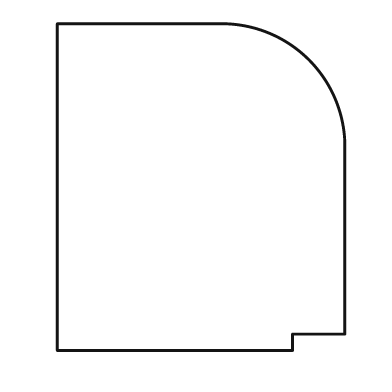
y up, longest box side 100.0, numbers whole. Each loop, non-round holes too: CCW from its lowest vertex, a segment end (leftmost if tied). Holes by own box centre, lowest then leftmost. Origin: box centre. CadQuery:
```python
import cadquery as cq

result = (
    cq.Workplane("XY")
    .moveTo(-44.0, -50.0)
    .lineTo(28.0, -50.0)
    .lineTo(28.0, -45.0)
    .lineTo(44.0, -45.0)
    .lineTo(44.0, 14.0)
    .threePointArc((33.0, 39.0), (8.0, 50.0))
    .lineTo(-44.0, 50.0)
    .close()
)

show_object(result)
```